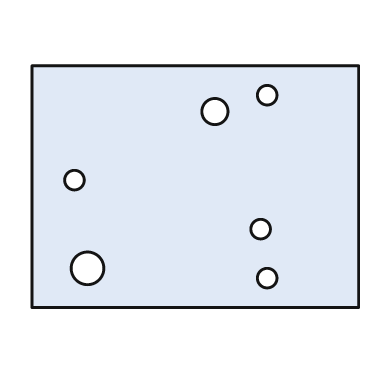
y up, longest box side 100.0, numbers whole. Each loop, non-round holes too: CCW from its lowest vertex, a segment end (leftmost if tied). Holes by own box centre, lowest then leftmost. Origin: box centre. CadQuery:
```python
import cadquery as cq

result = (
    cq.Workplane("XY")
    .moveTo(-50.0, -37.0)
    .lineTo(50.0, -37.0)
    .lineTo(50.0, 37.0)
    .lineTo(-50.0, 37.0)
    .close()
    .moveTo(22.0, -28.0)
    .circle(3.0)
    .moveTo(-33.0, -25.0)
    .circle(5.0)
    .moveTo(20.0, -13.0)
    .circle(3.0)
    .moveTo(-37.0, 2.0)
    .circle(3.0)
    .moveTo(6.0, 23.0)
    .circle(4.0)
    .moveTo(22.0, 28.0)
    .circle(3.0)
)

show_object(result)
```